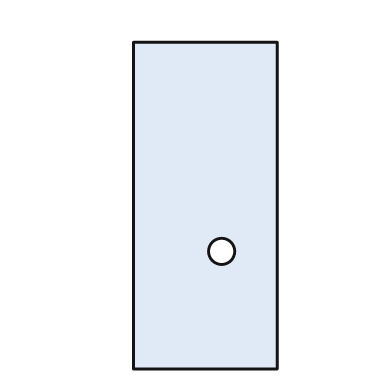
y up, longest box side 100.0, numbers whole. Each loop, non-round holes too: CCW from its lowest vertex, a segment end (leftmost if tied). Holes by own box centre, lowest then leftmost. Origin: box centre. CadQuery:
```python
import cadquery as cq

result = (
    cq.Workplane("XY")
    .moveTo(-22.0, -50.0)
    .lineTo(22.0, -50.0)
    .lineTo(22.0, 50.0)
    .lineTo(-22.0, 50.0)
    .close()
    .moveTo(5.0, -14.0)
    .circle(4.0)
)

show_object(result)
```